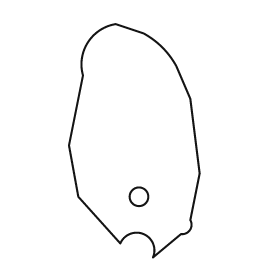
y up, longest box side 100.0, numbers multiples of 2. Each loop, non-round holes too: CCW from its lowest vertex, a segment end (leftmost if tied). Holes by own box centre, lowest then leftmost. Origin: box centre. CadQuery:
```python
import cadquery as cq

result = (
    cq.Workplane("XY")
    .moveTo(8.0, -50.0)
    .lineTo(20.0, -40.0)
    .threePointArc((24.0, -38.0), (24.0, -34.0))
    .lineTo(28.0, -14.0)
    .lineTo(24.0, 18.0)
    .lineTo(18.0, 32.0)
    .threePointArc((12.0, 40.0), (4.0, 46.0))
    .lineTo(-8.0, 50.0)
    .threePointArc((-20.0, 42.0), (-22.0, 28.0))
    .lineTo(-28.0, -2.0)
    .lineTo(-24.0, -24.0)
    .lineTo(-6.0, -44.0)
    .threePointArc((4.0, -40.0), (8.0, -50.0))
    .close()
    .moveTo(2.0, -24.0)
    .circle(4.0)
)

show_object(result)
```